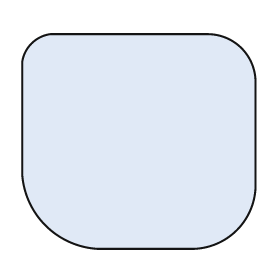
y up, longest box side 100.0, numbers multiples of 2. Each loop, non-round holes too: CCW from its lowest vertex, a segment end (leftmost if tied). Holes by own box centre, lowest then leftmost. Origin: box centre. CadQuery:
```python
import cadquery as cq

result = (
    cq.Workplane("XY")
    .moveTo(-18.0, -46.0)
    .lineTo(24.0, -46.0)
    .threePointArc((42.0, -38.0), (50.0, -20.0))
    .lineTo(50.0, 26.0)
    .threePointArc((44.0, 40.0), (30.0, 46.0))
    .lineTo(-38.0, 46.0)
    .threePointArc((-46.0, 42.0), (-50.0, 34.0))
    .lineTo(-50.0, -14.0)
    .threePointArc((-40.0, -36.0), (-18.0, -46.0))
    .close()
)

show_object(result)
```